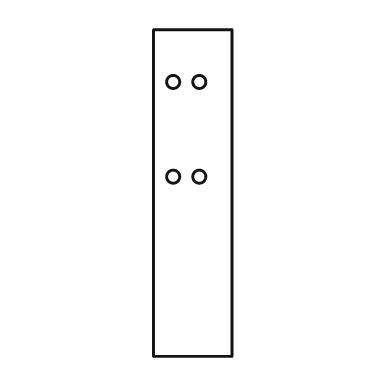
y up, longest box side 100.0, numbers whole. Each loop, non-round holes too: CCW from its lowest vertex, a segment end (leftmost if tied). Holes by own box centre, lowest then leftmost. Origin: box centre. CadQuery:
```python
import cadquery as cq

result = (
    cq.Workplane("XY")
    .moveTo(-12.0, -50.0)
    .lineTo(12.0, -50.0)
    .lineTo(12.0, 50.0)
    .lineTo(-12.0, 50.0)
    .close()
    .moveTo(-6.0, 5.0)
    .circle(2.0)
    .moveTo(2.0, 5.0)
    .circle(2.0)
    .moveTo(-6.0, 34.0)
    .circle(2.0)
    .moveTo(2.0, 34.0)
    .circle(2.0)
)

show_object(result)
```